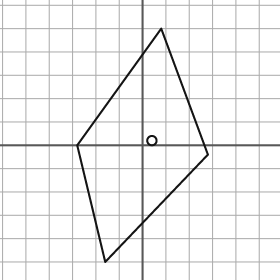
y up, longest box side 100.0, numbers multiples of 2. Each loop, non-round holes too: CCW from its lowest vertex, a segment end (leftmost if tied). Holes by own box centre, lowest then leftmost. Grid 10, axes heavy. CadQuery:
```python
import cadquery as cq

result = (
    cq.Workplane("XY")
    .moveTo(-16.0, -50.0)
    .lineTo(28.0, -4.0)
    .lineTo(8.0, 50.0)
    .lineTo(-28.0, 0.0)
    .close()
    .moveTo(4.0, 2.0)
    .circle(2.0)
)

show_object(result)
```